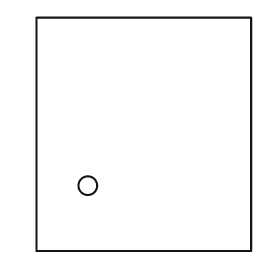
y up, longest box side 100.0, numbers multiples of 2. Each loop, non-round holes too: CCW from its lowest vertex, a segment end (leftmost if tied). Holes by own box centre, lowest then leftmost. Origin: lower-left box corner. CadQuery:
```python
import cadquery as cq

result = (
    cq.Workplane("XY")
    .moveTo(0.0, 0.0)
    .lineTo(92.0, 0.0)
    .lineTo(92.0, 100.0)
    .lineTo(0.0, 100.0)
    .close()
    .moveTo(22.0, 28.0)
    .circle(4.0)
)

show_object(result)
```